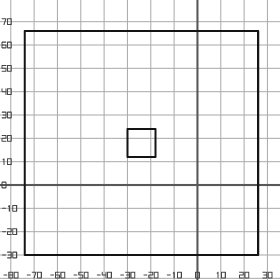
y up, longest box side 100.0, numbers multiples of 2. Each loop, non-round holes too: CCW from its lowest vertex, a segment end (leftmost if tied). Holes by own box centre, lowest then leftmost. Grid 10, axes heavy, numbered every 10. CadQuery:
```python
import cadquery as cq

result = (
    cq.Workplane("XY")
    .moveTo(-74.0, -30.0)
    .lineTo(26.0, -30.0)
    .lineTo(26.0, 66.0)
    .lineTo(-74.0, 66.0)
    .close()
    .moveTo(-30.0, 12.0)
    .lineTo(-18.0, 12.0)
    .lineTo(-18.0, 24.0)
    .lineTo(-30.0, 24.0)
    .close()
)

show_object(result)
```